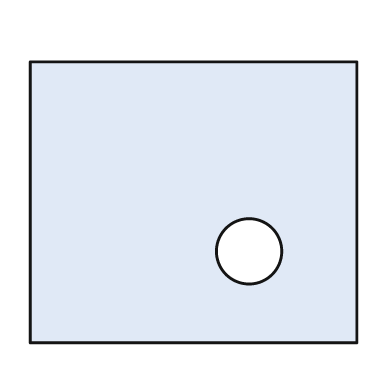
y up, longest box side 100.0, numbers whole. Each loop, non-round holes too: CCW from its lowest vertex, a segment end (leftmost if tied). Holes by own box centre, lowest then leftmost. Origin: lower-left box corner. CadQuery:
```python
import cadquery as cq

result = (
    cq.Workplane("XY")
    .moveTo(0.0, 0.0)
    .lineTo(100.0, 0.0)
    .lineTo(100.0, 86.0)
    .lineTo(0.0, 86.0)
    .close()
    .moveTo(67.0, 28.0)
    .circle(10.0)
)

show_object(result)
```